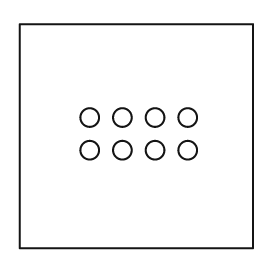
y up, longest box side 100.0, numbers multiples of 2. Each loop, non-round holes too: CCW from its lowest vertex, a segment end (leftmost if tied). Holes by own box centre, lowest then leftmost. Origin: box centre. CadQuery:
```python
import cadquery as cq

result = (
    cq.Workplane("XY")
    .moveTo(-50.0, -48.0)
    .lineTo(50.0, -48.0)
    .lineTo(50.0, 48.0)
    .lineTo(-50.0, 48.0)
    .close()
    .moveTo(-20.0, -6.0)
    .circle(4.0)
    .moveTo(-6.0, -6.0)
    .circle(4.0)
    .moveTo(8.0, -6.0)
    .circle(4.0)
    .moveTo(22.0, -6.0)
    .circle(4.0)
    .moveTo(-20.0, 8.0)
    .circle(4.0)
    .moveTo(-6.0, 8.0)
    .circle(4.0)
    .moveTo(8.0, 8.0)
    .circle(4.0)
    .moveTo(22.0, 8.0)
    .circle(4.0)
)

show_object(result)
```